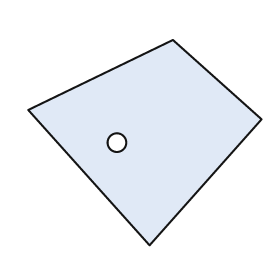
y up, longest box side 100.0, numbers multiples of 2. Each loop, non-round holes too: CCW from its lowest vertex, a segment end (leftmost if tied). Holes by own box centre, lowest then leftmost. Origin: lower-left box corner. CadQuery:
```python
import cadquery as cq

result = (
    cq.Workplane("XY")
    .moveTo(52.0, 0.0)
    .lineTo(100.0, 54.0)
    .lineTo(62.0, 88.0)
    .lineTo(0.0, 58.0)
    .close()
    .moveTo(38.0, 44.0)
    .circle(4.0)
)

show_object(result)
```